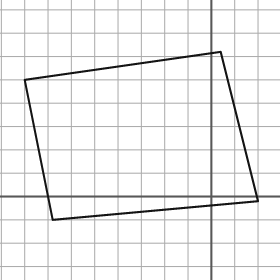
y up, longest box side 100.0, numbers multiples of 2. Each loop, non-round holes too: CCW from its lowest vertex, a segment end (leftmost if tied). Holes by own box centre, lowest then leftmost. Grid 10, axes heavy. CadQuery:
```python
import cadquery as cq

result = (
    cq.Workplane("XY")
    .moveTo(-68.0, -10.0)
    .lineTo(20.0, -2.0)
    .lineTo(4.0, 62.0)
    .lineTo(-80.0, 50.0)
    .close()
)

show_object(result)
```